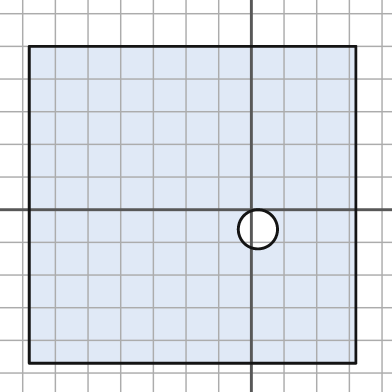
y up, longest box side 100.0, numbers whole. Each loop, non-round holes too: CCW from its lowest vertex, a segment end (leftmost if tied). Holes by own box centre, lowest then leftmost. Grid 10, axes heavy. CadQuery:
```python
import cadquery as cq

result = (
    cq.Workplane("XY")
    .moveTo(-68.0, -47.0)
    .lineTo(32.0, -47.0)
    .lineTo(32.0, 50.0)
    .lineTo(-68.0, 50.0)
    .close()
    .moveTo(2.0, -6.0)
    .circle(6.0)
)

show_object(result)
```